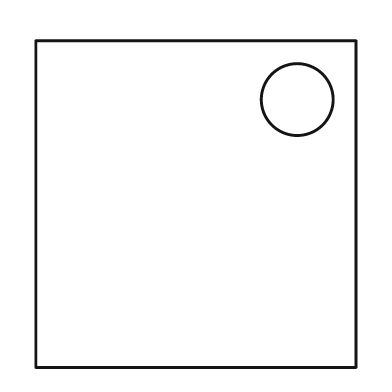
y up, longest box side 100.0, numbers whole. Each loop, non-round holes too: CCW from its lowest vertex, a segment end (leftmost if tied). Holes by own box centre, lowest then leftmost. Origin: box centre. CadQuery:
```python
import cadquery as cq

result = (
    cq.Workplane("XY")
    .moveTo(-49.0, -50.0)
    .lineTo(49.0, -50.0)
    .lineTo(49.0, 50.0)
    .lineTo(-49.0, 50.0)
    .close()
    .moveTo(31.0, 32.0)
    .circle(11.0)
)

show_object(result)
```